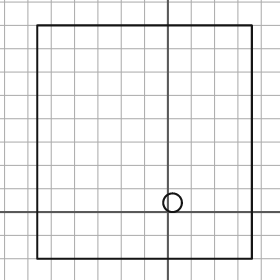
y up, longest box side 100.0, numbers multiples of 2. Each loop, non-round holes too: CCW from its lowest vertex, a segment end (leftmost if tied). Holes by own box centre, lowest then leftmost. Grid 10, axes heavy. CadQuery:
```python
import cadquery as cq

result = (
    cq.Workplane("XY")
    .moveTo(-56.0, -20.0)
    .lineTo(36.0, -20.0)
    .lineTo(36.0, 80.0)
    .lineTo(-56.0, 80.0)
    .close()
    .moveTo(2.0, 4.0)
    .circle(4.0)
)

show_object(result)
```